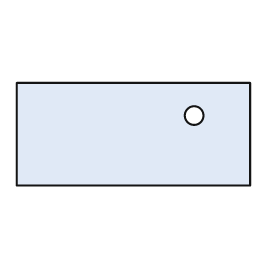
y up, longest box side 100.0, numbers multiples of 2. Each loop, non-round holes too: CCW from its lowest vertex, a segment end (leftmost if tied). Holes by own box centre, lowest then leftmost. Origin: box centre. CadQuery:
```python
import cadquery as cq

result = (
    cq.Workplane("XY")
    .moveTo(-50.0, -22.0)
    .lineTo(50.0, -22.0)
    .lineTo(50.0, 22.0)
    .lineTo(-50.0, 22.0)
    .close()
    .moveTo(26.0, 8.0)
    .circle(4.0)
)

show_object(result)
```